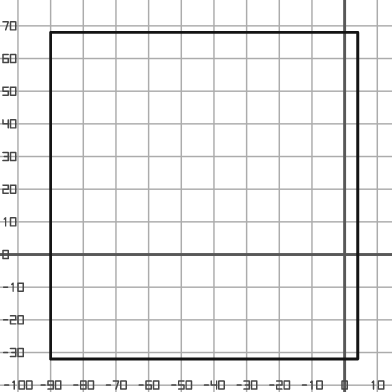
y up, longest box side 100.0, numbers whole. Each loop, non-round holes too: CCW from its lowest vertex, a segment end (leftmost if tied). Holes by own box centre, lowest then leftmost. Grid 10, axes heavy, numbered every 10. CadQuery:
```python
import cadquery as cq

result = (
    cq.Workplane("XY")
    .moveTo(-90.0, -32.0)
    .lineTo(4.0, -32.0)
    .lineTo(4.0, 68.0)
    .lineTo(-90.0, 68.0)
    .close()
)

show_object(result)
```